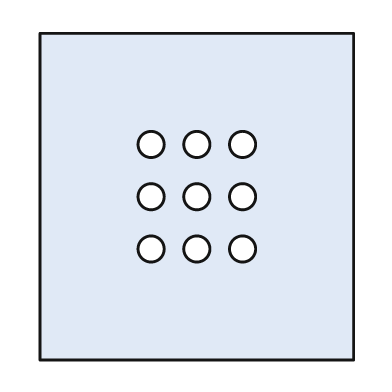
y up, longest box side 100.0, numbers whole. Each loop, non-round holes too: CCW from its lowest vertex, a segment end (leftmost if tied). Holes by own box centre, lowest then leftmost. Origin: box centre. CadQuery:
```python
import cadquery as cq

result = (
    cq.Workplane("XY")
    .moveTo(-48.0, -50.0)
    .lineTo(48.0, -50.0)
    .lineTo(48.0, 50.0)
    .lineTo(-48.0, 50.0)
    .close()
    .moveTo(-14.0, -16.0)
    .circle(4.0)
    .moveTo(0.0, -16.0)
    .circle(4.0)
    .moveTo(14.0, -16.0)
    .circle(4.0)
    .moveTo(-14.0, 0.0)
    .circle(4.0)
    .moveTo(0.0, 0.0)
    .circle(4.0)
    .moveTo(14.0, 0.0)
    .circle(4.0)
    .moveTo(-14.0, 16.0)
    .circle(4.0)
    .moveTo(0.0, 16.0)
    .circle(4.0)
    .moveTo(14.0, 16.0)
    .circle(4.0)
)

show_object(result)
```